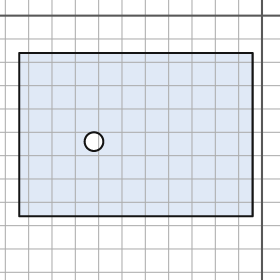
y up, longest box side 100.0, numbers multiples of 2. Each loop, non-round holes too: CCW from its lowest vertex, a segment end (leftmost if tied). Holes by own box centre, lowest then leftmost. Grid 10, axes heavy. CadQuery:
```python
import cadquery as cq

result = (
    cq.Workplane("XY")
    .moveTo(-104.0, -86.0)
    .lineTo(-4.0, -86.0)
    .lineTo(-4.0, -16.0)
    .lineTo(-104.0, -16.0)
    .close()
    .moveTo(-72.0, -54.0)
    .circle(4.0)
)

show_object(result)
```